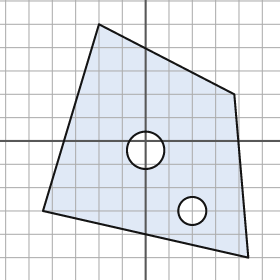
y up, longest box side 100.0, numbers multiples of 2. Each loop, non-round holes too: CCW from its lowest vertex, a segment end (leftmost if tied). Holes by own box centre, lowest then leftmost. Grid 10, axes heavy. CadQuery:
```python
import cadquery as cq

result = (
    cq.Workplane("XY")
    .moveTo(44.0, -50.0)
    .lineTo(38.0, 20.0)
    .lineTo(-20.0, 50.0)
    .lineTo(-44.0, -30.0)
    .close()
    .moveTo(20.0, -30.0)
    .circle(6.0)
    .moveTo(0.0, -4.0)
    .circle(8.0)
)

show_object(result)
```